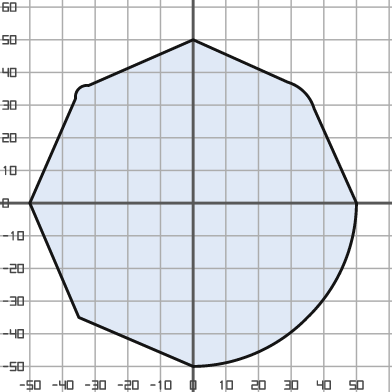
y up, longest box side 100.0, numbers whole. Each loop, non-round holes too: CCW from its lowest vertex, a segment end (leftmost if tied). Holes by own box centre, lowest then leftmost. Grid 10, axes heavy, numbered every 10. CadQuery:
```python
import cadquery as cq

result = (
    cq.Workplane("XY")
    .moveTo(0.0, -50.0)
    .threePointArc((19.0, -46.0), (35.0, -35.0))
    .threePointArc((46.0, -19.0), (50.0, 0.0))
    .lineTo(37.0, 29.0)
    .threePointArc((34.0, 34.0), (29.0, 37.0))
    .lineTo(0.0, 50.0)
    .lineTo(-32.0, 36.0)
    .threePointArc((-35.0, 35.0), (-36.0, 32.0))
    .lineTo(-50.0, 0.0)
    .lineTo(-35.0, -35.0)
    .close()
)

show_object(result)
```